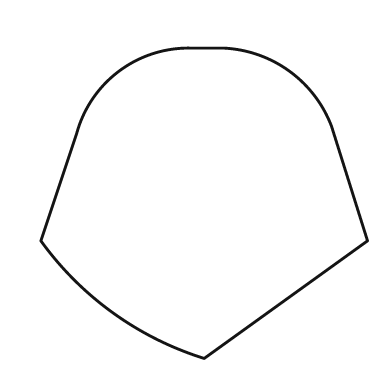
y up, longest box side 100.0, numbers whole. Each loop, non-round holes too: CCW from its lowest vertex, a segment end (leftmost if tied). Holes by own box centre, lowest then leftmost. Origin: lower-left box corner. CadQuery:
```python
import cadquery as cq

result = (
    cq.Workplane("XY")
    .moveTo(50.0, 0.0)
    .lineTo(100.0, 36.0)
    .lineTo(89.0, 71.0)
    .threePointArc((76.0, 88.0), (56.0, 95.0))
    .lineTo(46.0, 95.0)
    .threePointArc((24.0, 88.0), (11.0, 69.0))
    .lineTo(0.0, 36.0)
    .threePointArc((22.0, 14.0), (50.0, 0.0))
    .close()
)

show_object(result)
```